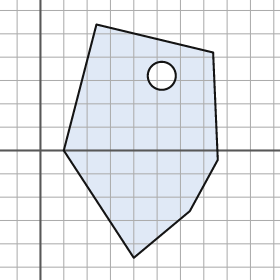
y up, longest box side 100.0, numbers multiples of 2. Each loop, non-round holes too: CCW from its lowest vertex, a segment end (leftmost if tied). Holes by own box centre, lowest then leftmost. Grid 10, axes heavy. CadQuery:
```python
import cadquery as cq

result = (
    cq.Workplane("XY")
    .moveTo(40.0, -46.0)
    .lineTo(64.0, -26.0)
    .lineTo(76.0, -4.0)
    .lineTo(74.0, 42.0)
    .lineTo(24.0, 54.0)
    .lineTo(10.0, 0.0)
    .close()
    .moveTo(52.0, 32.0)
    .circle(6.0)
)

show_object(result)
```